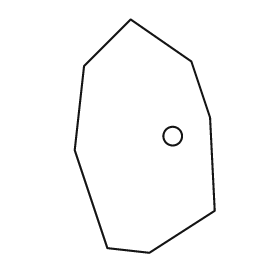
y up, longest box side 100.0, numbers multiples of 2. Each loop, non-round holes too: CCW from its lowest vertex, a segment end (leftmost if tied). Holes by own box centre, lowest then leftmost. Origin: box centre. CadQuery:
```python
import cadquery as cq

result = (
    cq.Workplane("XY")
    .moveTo(2.0, -50.0)
    .lineTo(30.0, -32.0)
    .lineTo(28.0, 8.0)
    .lineTo(20.0, 32.0)
    .lineTo(-6.0, 50.0)
    .lineTo(-26.0, 30.0)
    .lineTo(-30.0, -6.0)
    .lineTo(-16.0, -48.0)
    .close()
    .moveTo(12.0, 0.0)
    .circle(4.0)
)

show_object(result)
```